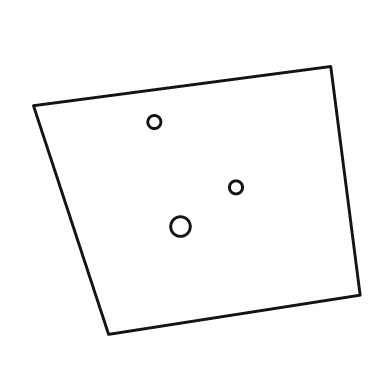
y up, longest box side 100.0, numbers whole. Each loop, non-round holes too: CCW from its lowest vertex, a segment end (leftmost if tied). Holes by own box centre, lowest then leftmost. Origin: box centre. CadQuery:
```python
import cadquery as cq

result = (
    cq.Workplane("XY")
    .moveTo(-27.0, -41.0)
    .lineTo(50.0, -29.0)
    .lineTo(41.0, 41.0)
    .lineTo(-50.0, 29.0)
    .close()
    .moveTo(-5.0, -8.0)
    .circle(3.0)
    .moveTo(12.0, 4.0)
    .circle(2.0)
    .moveTo(-13.0, 24.0)
    .circle(2.0)
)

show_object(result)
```